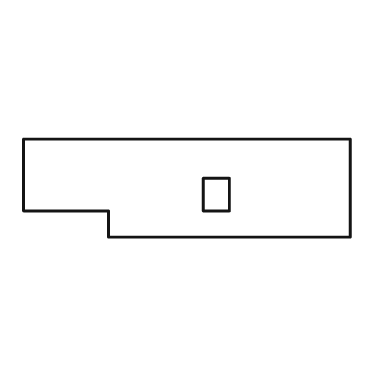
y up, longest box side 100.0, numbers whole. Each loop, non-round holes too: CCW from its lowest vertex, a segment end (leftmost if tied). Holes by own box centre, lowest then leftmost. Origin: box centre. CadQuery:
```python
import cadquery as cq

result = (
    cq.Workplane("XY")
    .moveTo(-24.0, -15.0)
    .lineTo(50.0, -15.0)
    .lineTo(50.0, 15.0)
    .lineTo(-50.0, 15.0)
    .lineTo(-50.0, -7.0)
    .lineTo(-24.0, -7.0)
    .close()
    .moveTo(5.0, -7.0)
    .lineTo(13.0, -7.0)
    .lineTo(13.0, 3.0)
    .lineTo(5.0, 3.0)
    .close()
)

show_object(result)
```